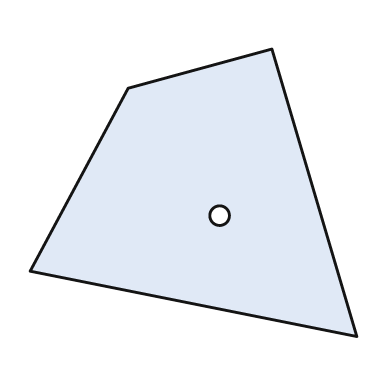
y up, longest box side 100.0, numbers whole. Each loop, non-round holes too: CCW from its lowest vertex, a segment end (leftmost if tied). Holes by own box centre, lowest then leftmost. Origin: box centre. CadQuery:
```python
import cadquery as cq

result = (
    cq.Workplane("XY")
    .moveTo(50.0, -44.0)
    .lineTo(24.0, 44.0)
    .lineTo(-20.0, 32.0)
    .lineTo(-50.0, -24.0)
    .close()
    .moveTo(8.0, -7.0)
    .circle(3.0)
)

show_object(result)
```